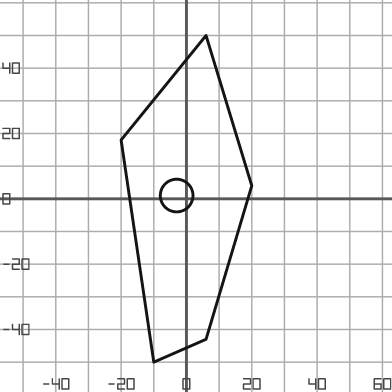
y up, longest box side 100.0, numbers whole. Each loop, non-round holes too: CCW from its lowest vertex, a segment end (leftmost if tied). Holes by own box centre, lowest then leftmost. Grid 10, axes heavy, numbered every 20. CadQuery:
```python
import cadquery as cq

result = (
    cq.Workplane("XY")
    .moveTo(-10.0, -50.0)
    .lineTo(6.0, -43.0)
    .lineTo(20.0, 4.0)
    .lineTo(6.0, 50.0)
    .lineTo(-20.0, 18.0)
    .close()
    .moveTo(-3.0, 1.0)
    .circle(5.0)
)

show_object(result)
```